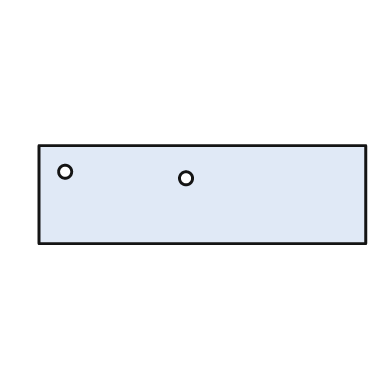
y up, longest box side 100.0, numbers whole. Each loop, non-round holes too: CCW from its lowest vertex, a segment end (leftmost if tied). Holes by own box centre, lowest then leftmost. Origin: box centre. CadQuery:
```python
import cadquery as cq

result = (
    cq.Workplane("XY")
    .moveTo(-50.0, -15.0)
    .lineTo(50.0, -15.0)
    .lineTo(50.0, 15.0)
    .lineTo(-50.0, 15.0)
    .close()
    .moveTo(-5.0, 5.0)
    .circle(2.0)
    .moveTo(-42.0, 7.0)
    .circle(2.0)
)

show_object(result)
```